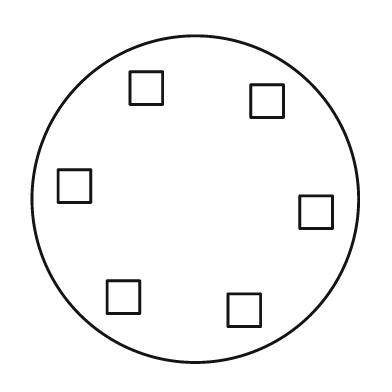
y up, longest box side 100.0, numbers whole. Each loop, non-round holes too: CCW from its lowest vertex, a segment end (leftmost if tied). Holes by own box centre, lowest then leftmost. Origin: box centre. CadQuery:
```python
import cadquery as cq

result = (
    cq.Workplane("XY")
    .moveTo(0.0, 0.0)
    .circle(50.0)
    .moveTo(10.0, -39.0)
    .lineTo(20.0, -39.0)
    .lineTo(20.0, -29.0)
    .lineTo(10.0, -29.0)
    .close()
    .moveTo(-27.0, -35.0)
    .lineTo(-17.0, -35.0)
    .lineTo(-17.0, -25.0)
    .lineTo(-27.0, -25.0)
    .close()
    .moveTo(32.0, -9.0)
    .lineTo(42.0, -9.0)
    .lineTo(42.0, 1.0)
    .lineTo(32.0, 1.0)
    .close()
    .moveTo(-42.0, -1.0)
    .lineTo(-32.0, -1.0)
    .lineTo(-32.0, 9.0)
    .lineTo(-42.0, 9.0)
    .close()
    .moveTo(17.0, 25.0)
    .lineTo(27.0, 25.0)
    .lineTo(27.0, 35.0)
    .lineTo(17.0, 35.0)
    .close()
    .moveTo(-20.0, 29.0)
    .lineTo(-10.0, 29.0)
    .lineTo(-10.0, 39.0)
    .lineTo(-20.0, 39.0)
    .close()
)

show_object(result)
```